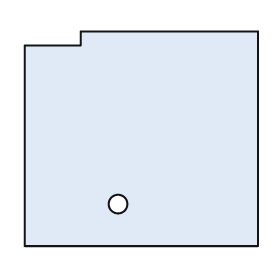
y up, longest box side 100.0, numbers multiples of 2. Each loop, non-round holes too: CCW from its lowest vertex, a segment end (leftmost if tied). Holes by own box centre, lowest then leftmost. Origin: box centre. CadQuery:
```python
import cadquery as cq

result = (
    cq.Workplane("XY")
    .moveTo(-50.0, -46.0)
    .lineTo(50.0, -46.0)
    .lineTo(50.0, 46.0)
    .lineTo(-26.0, 46.0)
    .lineTo(-26.0, 40.0)
    .lineTo(-50.0, 40.0)
    .close()
    .moveTo(-10.0, -28.0)
    .circle(4.0)
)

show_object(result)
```